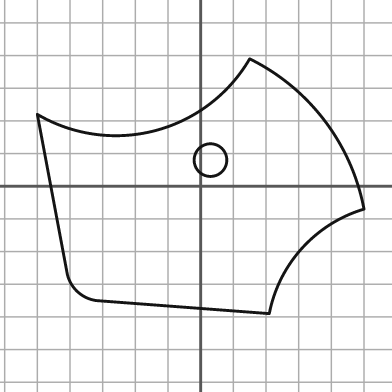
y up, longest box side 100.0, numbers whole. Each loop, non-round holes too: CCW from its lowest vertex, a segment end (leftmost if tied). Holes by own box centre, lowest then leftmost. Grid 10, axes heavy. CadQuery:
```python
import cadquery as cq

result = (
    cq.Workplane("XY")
    .moveTo(21.0, -39.0)
    .threePointArc((31.0, -19.0), (50.0, -7.0))
    .threePointArc((38.0, 20.0), (15.0, 39.0))
    .threePointArc((-14.0, 17.0), (-50.0, 22.0))
    .lineTo(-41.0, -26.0)
    .threePointArc((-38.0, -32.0), (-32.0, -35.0))
    .close()
    .moveTo(3.0, 8.0)
    .circle(5.0)
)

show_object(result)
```